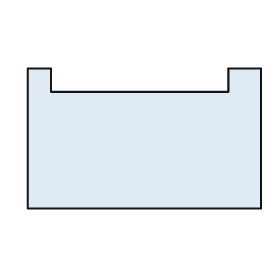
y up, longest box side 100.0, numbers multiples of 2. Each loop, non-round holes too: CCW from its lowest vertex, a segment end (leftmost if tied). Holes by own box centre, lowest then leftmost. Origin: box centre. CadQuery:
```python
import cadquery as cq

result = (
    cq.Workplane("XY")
    .moveTo(-50.0, -30.0)
    .lineTo(50.0, -30.0)
    .lineTo(50.0, 30.0)
    .lineTo(36.0, 30.0)
    .lineTo(36.0, 20.0)
    .lineTo(-40.0, 20.0)
    .lineTo(-40.0, 30.0)
    .lineTo(-50.0, 30.0)
    .close()
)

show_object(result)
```